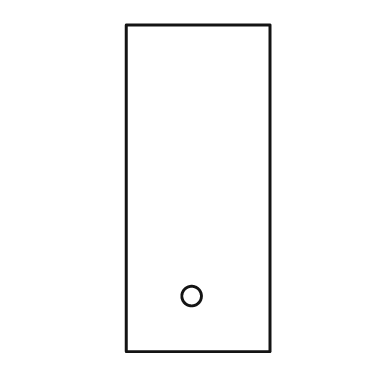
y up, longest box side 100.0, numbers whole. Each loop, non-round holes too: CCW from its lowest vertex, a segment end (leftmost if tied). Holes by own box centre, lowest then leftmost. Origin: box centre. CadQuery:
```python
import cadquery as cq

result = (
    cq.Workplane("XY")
    .moveTo(-22.0, -50.0)
    .lineTo(22.0, -50.0)
    .lineTo(22.0, 50.0)
    .lineTo(-22.0, 50.0)
    .close()
    .moveTo(-2.0, -33.0)
    .circle(3.0)
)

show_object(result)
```